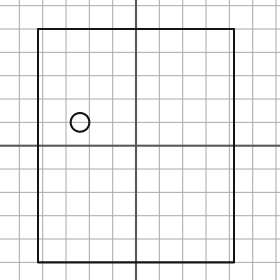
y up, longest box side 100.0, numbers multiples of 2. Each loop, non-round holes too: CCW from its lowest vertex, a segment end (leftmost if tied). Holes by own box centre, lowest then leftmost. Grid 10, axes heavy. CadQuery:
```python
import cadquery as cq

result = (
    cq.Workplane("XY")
    .moveTo(-42.0, -50.0)
    .lineTo(42.0, -50.0)
    .lineTo(42.0, 50.0)
    .lineTo(-42.0, 50.0)
    .close()
    .moveTo(-24.0, 10.0)
    .circle(4.0)
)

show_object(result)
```